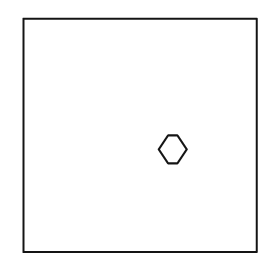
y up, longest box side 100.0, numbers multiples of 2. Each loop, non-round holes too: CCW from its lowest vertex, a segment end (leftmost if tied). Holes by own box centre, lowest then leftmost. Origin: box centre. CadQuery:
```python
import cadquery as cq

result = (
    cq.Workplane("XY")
    .moveTo(-50.0, -50.0)
    .lineTo(50.0, -50.0)
    .lineTo(50.0, 50.0)
    .lineTo(-50.0, 50.0)
    .close()
    .moveTo(12.0, -12.0)
    .lineTo(16.0, -12.0)
    .lineTo(20.0, -6.0)
    .lineTo(16.0, 0.0)
    .lineTo(12.0, 0.0)
    .lineTo(8.0, -6.0)
    .close()
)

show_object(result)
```